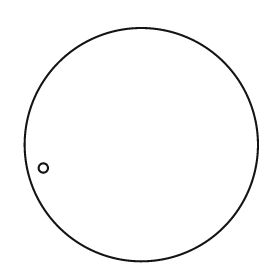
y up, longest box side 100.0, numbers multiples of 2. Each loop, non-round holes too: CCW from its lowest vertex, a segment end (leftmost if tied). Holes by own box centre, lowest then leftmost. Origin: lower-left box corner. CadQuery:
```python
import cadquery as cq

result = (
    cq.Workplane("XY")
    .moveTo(50.0, 50.0)
    .circle(50.0)
    .moveTo(8.0, 40.0)
    .circle(2.0)
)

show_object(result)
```